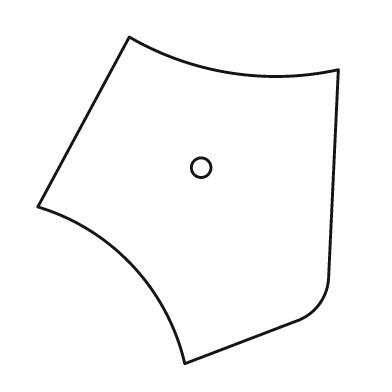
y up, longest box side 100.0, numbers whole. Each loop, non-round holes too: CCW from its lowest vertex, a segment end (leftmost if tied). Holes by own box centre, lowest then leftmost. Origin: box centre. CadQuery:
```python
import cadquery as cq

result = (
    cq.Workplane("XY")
    .moveTo(-1.0, -50.0)
    .lineTo(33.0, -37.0)
    .threePointArc((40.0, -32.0), (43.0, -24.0))
    .lineTo(46.0, 40.0)
    .threePointArc((13.0, 39.0), (-18.0, 50.0))
    .lineTo(-46.0, -2.0)
    .threePointArc((-17.0, -20.0), (-1.0, -50.0))
    .close()
    .moveTo(4.0, 10.0)
    .circle(3.0)
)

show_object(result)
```